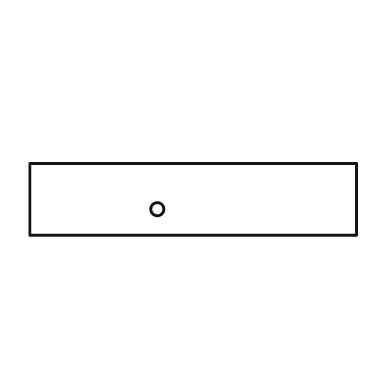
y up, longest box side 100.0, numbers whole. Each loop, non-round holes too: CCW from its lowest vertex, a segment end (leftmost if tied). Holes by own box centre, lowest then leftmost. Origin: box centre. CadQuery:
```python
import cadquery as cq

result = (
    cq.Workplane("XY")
    .moveTo(-50.0, -11.0)
    .lineTo(50.0, -11.0)
    .lineTo(50.0, 11.0)
    .lineTo(-50.0, 11.0)
    .close()
    .moveTo(-11.0, -3.0)
    .circle(2.0)
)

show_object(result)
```